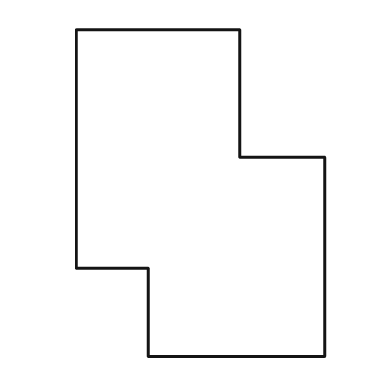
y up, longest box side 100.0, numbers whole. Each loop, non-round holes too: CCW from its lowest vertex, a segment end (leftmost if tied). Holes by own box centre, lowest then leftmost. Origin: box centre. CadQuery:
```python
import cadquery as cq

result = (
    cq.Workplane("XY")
    .moveTo(-16.0, -50.0)
    .lineTo(38.0, -50.0)
    .lineTo(38.0, 11.0)
    .lineTo(12.0, 11.0)
    .lineTo(12.0, 50.0)
    .lineTo(-38.0, 50.0)
    .lineTo(-38.0, -23.0)
    .lineTo(-16.0, -23.0)
    .close()
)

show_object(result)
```